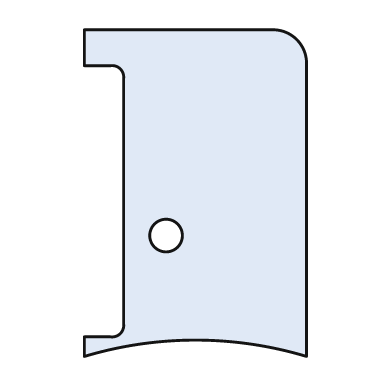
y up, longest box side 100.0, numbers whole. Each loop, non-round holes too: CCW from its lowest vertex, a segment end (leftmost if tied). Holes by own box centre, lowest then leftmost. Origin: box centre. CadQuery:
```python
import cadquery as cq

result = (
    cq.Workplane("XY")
    .moveTo(-34.0, -50.0)
    .threePointArc((0.0, -45.0), (34.0, -50.0))
    .lineTo(34.0, 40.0)
    .threePointArc((31.0, 47.0), (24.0, 50.0))
    .lineTo(-34.0, 50.0)
    .lineTo(-34.0, 39.0)
    .lineTo(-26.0, 39.0)
    .threePointArc((-23.0, 38.0), (-22.0, 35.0))
    .lineTo(-22.0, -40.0)
    .threePointArc((-23.0, -43.0), (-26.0, -44.0))
    .lineTo(-34.0, -44.0)
    .close()
    .moveTo(-9.0, -13.0)
    .circle(5.0)
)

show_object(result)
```